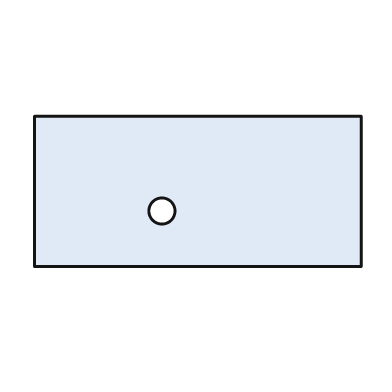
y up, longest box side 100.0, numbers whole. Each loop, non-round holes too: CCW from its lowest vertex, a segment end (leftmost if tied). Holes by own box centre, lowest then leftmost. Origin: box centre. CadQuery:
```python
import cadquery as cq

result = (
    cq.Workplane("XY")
    .moveTo(-50.0, -23.0)
    .lineTo(50.0, -23.0)
    .lineTo(50.0, 23.0)
    .lineTo(-50.0, 23.0)
    .close()
    .moveTo(-11.0, -6.0)
    .circle(4.0)
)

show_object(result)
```